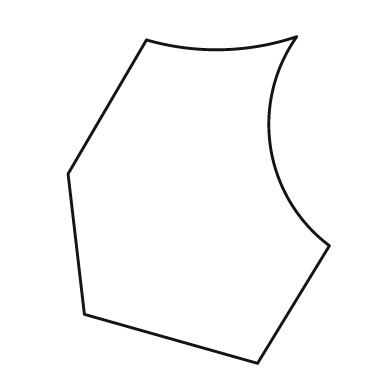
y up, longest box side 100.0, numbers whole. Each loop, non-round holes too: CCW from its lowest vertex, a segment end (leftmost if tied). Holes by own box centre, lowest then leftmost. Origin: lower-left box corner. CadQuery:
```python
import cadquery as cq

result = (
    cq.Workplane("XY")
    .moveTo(58.0, 0.0)
    .lineTo(80.0, 36.0)
    .threePointArc((62.0, 66.0), (70.0, 100.0))
    .threePointArc((47.0, 96.0), (24.0, 99.0))
    .lineTo(0.0, 58.0)
    .lineTo(5.0, 15.0)
    .close()
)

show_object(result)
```